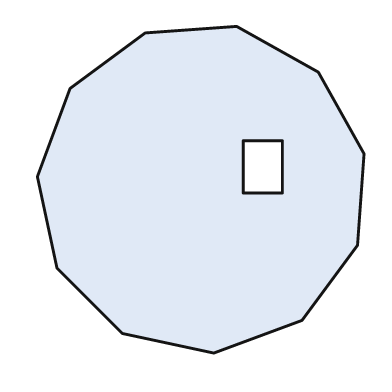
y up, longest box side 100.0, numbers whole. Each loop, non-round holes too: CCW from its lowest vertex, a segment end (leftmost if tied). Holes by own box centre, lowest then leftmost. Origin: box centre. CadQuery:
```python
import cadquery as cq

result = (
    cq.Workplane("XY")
    .moveTo(4.0, -50.0)
    .lineTo(31.0, -40.0)
    .lineTo(48.0, -17.0)
    .lineTo(50.0, 11.0)
    .lineTo(36.0, 36.0)
    .lineTo(11.0, 50.0)
    .lineTo(-17.0, 48.0)
    .lineTo(-40.0, 31.0)
    .lineTo(-50.0, 4.0)
    .lineTo(-44.0, -24.0)
    .lineTo(-24.0, -44.0)
    .close()
    .moveTo(13.0, -1.0)
    .lineTo(25.0, -1.0)
    .lineTo(25.0, 15.0)
    .lineTo(13.0, 15.0)
    .close()
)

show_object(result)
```